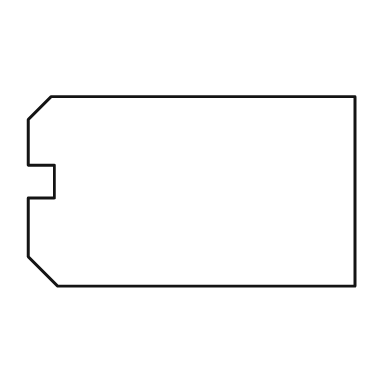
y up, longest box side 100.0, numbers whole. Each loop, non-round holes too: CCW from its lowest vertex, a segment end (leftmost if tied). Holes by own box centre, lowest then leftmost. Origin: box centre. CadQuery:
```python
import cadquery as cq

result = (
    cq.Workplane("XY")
    .moveTo(-41.0, -29.0)
    .lineTo(50.0, -29.0)
    .lineTo(50.0, 29.0)
    .lineTo(-43.0, 29.0)
    .lineTo(-50.0, 22.0)
    .lineTo(-50.0, 8.0)
    .lineTo(-42.0, 8.0)
    .lineTo(-42.0, -2.0)
    .lineTo(-50.0, -2.0)
    .lineTo(-50.0, -20.0)
    .close()
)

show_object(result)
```